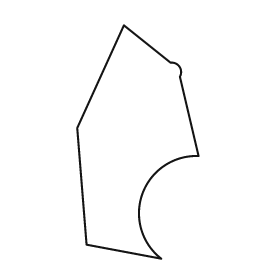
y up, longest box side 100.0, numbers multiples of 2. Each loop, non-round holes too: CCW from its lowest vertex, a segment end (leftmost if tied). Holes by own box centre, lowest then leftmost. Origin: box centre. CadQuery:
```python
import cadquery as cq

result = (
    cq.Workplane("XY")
    .moveTo(10.0, -50.0)
    .threePointArc((2.0, -22.0), (26.0, -6.0))
    .lineTo(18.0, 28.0)
    .threePointArc((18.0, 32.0), (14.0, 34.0))
    .lineTo(-6.0, 50.0)
    .lineTo(-26.0, 6.0)
    .lineTo(-22.0, -44.0)
    .close()
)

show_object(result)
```